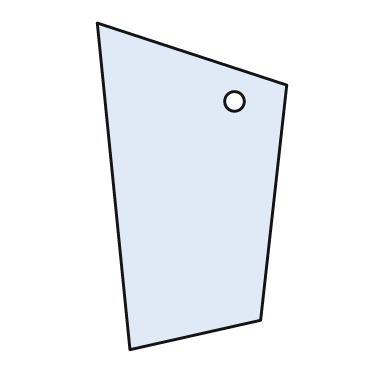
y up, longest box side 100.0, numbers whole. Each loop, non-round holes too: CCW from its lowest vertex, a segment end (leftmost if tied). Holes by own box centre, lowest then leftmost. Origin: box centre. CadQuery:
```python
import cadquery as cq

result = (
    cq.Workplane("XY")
    .moveTo(-19.0, -50.0)
    .lineTo(21.0, -41.0)
    .lineTo(29.0, 31.0)
    .lineTo(-29.0, 50.0)
    .close()
    .moveTo(13.0, 26.0)
    .circle(3.0)
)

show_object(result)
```